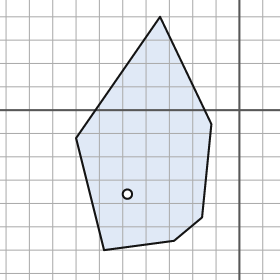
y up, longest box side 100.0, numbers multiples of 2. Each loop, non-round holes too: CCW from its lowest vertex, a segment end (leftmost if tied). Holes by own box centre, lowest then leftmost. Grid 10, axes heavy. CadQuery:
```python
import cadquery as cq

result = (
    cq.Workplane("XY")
    .moveTo(-58.0, -60.0)
    .lineTo(-28.0, -56.0)
    .lineTo(-16.0, -46.0)
    .lineTo(-12.0, -6.0)
    .lineTo(-34.0, 40.0)
    .lineTo(-70.0, -12.0)
    .close()
    .moveTo(-48.0, -36.0)
    .circle(2.0)
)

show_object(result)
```